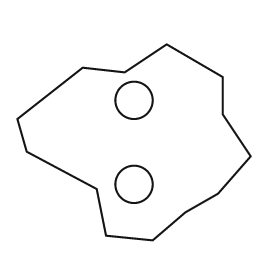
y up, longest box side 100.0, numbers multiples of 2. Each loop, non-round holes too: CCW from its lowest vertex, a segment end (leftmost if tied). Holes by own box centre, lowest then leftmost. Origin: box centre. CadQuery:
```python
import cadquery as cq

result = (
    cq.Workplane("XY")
    .moveTo(8.0, -42.0)
    .lineTo(22.0, -30.0)
    .lineTo(36.0, -22.0)
    .lineTo(50.0, -6.0)
    .lineTo(38.0, 12.0)
    .lineTo(38.0, 28.0)
    .lineTo(14.0, 42.0)
    .lineTo(-4.0, 30.0)
    .lineTo(-22.0, 32.0)
    .lineTo(-50.0, 10.0)
    .lineTo(-46.0, -4.0)
    .lineTo(-16.0, -20.0)
    .lineTo(-12.0, -40.0)
    .close()
    .moveTo(0.0, -18.0)
    .circle(8.0)
    .moveTo(0.0, 18.0)
    .circle(8.0)
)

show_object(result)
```